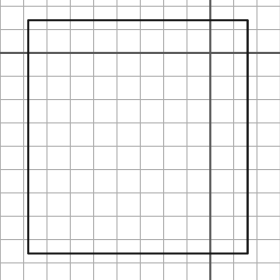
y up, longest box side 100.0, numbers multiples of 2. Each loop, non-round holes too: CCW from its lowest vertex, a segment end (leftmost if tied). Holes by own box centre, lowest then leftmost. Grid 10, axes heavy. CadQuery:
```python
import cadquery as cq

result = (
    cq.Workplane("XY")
    .moveTo(-78.0, -86.0)
    .lineTo(16.0, -86.0)
    .lineTo(16.0, 14.0)
    .lineTo(-78.0, 14.0)
    .close()
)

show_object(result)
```